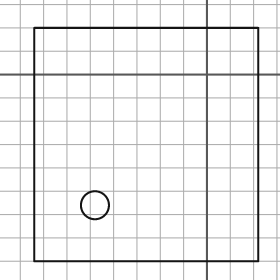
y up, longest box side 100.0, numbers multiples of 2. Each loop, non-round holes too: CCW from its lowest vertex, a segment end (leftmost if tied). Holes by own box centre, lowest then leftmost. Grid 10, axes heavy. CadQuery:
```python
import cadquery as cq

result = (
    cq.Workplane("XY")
    .moveTo(-74.0, -80.0)
    .lineTo(22.0, -80.0)
    .lineTo(22.0, 20.0)
    .lineTo(-74.0, 20.0)
    .close()
    .moveTo(-48.0, -56.0)
    .circle(6.0)
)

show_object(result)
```